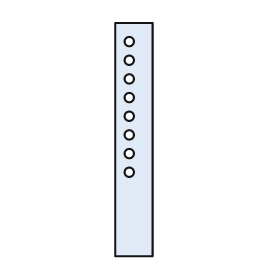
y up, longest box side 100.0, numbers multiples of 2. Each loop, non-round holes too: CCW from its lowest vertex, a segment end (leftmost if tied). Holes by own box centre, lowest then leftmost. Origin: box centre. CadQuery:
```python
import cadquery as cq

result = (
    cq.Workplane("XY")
    .moveTo(-8.0, -50.0)
    .lineTo(8.0, -50.0)
    .lineTo(8.0, 50.0)
    .lineTo(-8.0, 50.0)
    .close()
    .moveTo(-2.0, -14.0)
    .circle(2.0)
    .moveTo(-2.0, -6.0)
    .circle(2.0)
    .moveTo(-2.0, 2.0)
    .circle(2.0)
    .moveTo(-2.0, 10.0)
    .circle(2.0)
    .moveTo(-2.0, 18.0)
    .circle(2.0)
    .moveTo(-2.0, 26.0)
    .circle(2.0)
    .moveTo(-2.0, 34.0)
    .circle(2.0)
    .moveTo(-2.0, 42.0)
    .circle(2.0)
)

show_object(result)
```